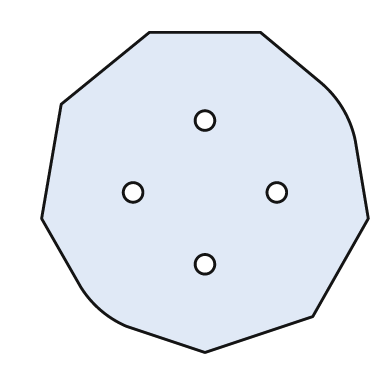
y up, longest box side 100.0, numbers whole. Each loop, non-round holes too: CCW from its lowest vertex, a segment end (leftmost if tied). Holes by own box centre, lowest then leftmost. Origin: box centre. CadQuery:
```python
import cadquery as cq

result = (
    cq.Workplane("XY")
    .moveTo(0.0, -49.0)
    .lineTo(33.0, -38.0)
    .lineTo(50.0, -8.0)
    .lineTo(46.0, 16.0)
    .threePointArc((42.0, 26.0), (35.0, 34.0))
    .lineTo(17.0, 49.0)
    .lineTo(-17.0, 49.0)
    .lineTo(-44.0, 27.0)
    .lineTo(-50.0, -8.0)
    .lineTo(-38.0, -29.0)
    .threePointArc((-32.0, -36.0), (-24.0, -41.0))
    .close()
    .moveTo(0.0, -22.0)
    .circle(3.0)
    .moveTo(-22.0, 0.0)
    .circle(3.0)
    .moveTo(22.0, 0.0)
    .circle(3.0)
    .moveTo(0.0, 22.0)
    .circle(3.0)
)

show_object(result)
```